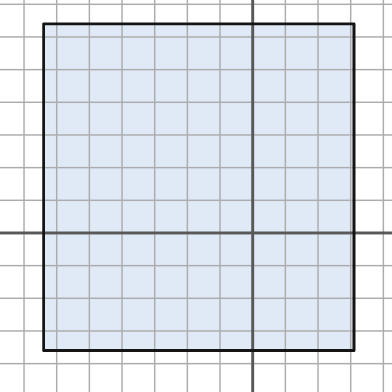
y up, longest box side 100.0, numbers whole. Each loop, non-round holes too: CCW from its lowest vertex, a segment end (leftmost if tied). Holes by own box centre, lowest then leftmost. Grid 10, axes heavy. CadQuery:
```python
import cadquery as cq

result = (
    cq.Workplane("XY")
    .moveTo(-64.0, -36.0)
    .lineTo(31.0, -36.0)
    .lineTo(31.0, 64.0)
    .lineTo(-64.0, 64.0)
    .close()
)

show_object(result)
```